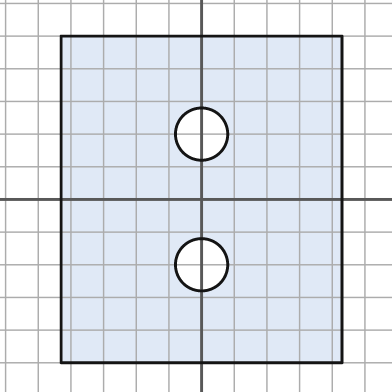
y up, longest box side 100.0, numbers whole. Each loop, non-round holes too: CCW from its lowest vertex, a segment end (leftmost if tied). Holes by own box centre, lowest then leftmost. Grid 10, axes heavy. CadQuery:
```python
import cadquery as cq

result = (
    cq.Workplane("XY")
    .moveTo(-43.0, -50.0)
    .lineTo(43.0, -50.0)
    .lineTo(43.0, 50.0)
    .lineTo(-43.0, 50.0)
    .close()
    .moveTo(0.0, -20.0)
    .circle(8.0)
    .moveTo(0.0, 20.0)
    .circle(8.0)
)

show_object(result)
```